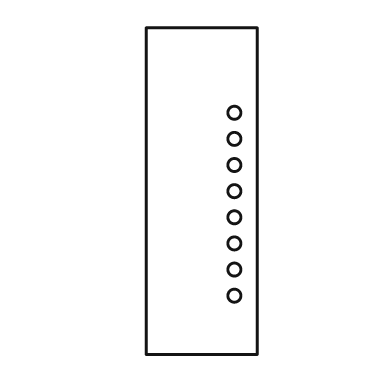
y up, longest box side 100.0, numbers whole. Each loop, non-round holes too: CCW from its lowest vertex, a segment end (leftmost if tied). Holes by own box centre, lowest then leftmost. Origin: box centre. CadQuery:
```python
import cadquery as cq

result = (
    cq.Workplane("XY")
    .moveTo(-17.0, -50.0)
    .lineTo(17.0, -50.0)
    .lineTo(17.0, 50.0)
    .lineTo(-17.0, 50.0)
    .close()
    .moveTo(10.0, -32.0)
    .circle(2.0)
    .moveTo(10.0, -24.0)
    .circle(2.0)
    .moveTo(10.0, -16.0)
    .circle(2.0)
    .moveTo(10.0, -8.0)
    .circle(2.0)
    .moveTo(10.0, 0.0)
    .circle(2.0)
    .moveTo(10.0, 8.0)
    .circle(2.0)
    .moveTo(10.0, 16.0)
    .circle(2.0)
    .moveTo(10.0, 24.0)
    .circle(2.0)
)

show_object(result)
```